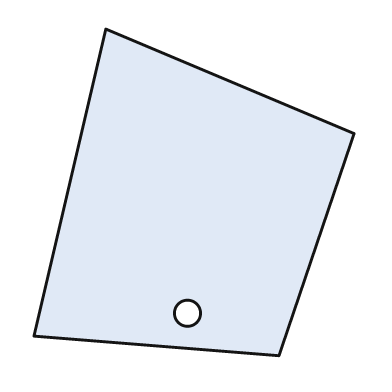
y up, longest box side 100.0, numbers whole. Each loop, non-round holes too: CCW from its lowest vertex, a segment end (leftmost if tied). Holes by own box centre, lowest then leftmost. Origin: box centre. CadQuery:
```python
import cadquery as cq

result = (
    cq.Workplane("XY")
    .moveTo(26.0, -50.0)
    .lineTo(49.0, 18.0)
    .lineTo(-27.0, 50.0)
    .lineTo(-49.0, -44.0)
    .close()
    .moveTo(-2.0, -37.0)
    .circle(4.0)
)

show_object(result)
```